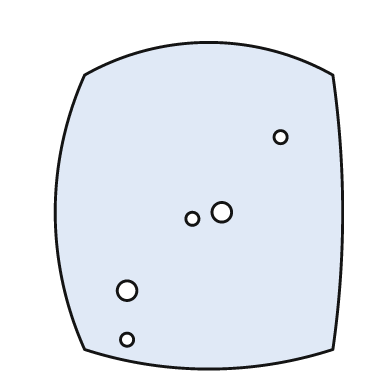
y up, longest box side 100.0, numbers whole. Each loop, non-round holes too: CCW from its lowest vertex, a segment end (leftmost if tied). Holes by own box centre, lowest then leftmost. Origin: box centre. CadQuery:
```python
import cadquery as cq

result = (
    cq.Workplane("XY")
    .moveTo(-35.0, -44.0)
    .threePointArc((3.0, -50.0), (41.0, -44.0))
    .threePointArc((44.0, -2.0), (41.0, 40.0))
    .threePointArc((3.0, 50.0), (-35.0, 40.0))
    .threePointArc((-44.0, -2.0), (-35.0, -44.0))
    .close()
    .moveTo(-22.0, -41.0)
    .circle(2.0)
    .moveTo(-22.0, -26.0)
    .circle(3.0)
    .moveTo(-2.0, -4.0)
    .circle(2.0)
    .moveTo(7.0, -2.0)
    .circle(3.0)
    .moveTo(25.0, 21.0)
    .circle(2.0)
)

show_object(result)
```